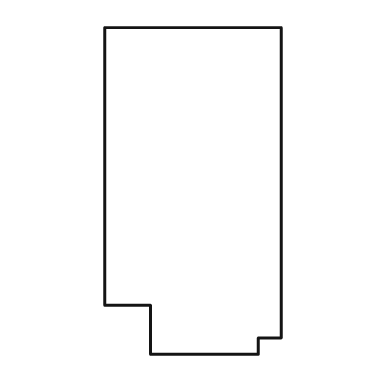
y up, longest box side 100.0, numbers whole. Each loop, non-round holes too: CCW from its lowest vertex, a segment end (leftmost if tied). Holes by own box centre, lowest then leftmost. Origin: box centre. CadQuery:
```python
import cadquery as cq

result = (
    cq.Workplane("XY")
    .moveTo(-13.0, -50.0)
    .lineTo(20.0, -50.0)
    .lineTo(20.0, -45.0)
    .lineTo(27.0, -45.0)
    .lineTo(27.0, 50.0)
    .lineTo(-27.0, 50.0)
    .lineTo(-27.0, -35.0)
    .lineTo(-13.0, -35.0)
    .close()
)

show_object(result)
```